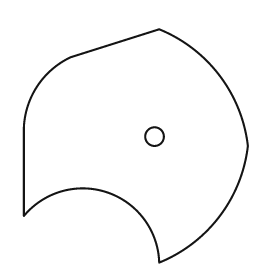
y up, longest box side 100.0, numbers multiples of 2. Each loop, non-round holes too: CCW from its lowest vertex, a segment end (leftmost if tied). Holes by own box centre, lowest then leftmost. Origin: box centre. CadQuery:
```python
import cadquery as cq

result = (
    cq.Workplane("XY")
    .moveTo(10.0, -50.0)
    .threePointArc((36.0, -30.0), (48.0, 0.0))
    .threePointArc((36.0, 30.0), (10.0, 50.0))
    .lineTo(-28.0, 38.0)
    .threePointArc((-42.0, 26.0), (-48.0, 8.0))
    .lineTo(-48.0, -30.0)
    .threePointArc((-12.0, -20.0), (10.0, -50.0))
    .close()
    .moveTo(8.0, 4.0)
    .circle(4.0)
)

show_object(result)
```